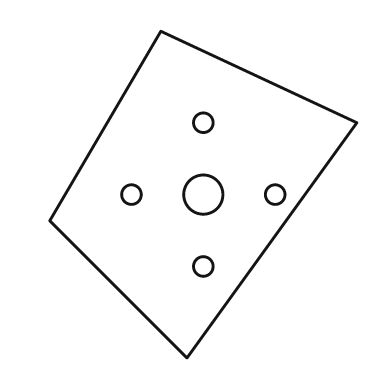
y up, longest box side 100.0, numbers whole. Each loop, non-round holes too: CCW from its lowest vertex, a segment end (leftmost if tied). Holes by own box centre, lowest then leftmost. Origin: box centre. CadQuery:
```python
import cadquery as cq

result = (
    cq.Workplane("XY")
    .moveTo(-5.0, -50.0)
    .lineTo(47.0, 22.0)
    .lineTo(-13.0, 50.0)
    .lineTo(-47.0, -8.0)
    .close()
    .moveTo(0.0, -22.0)
    .circle(3.0)
    .moveTo(-22.0, 0.0)
    .circle(3.0)
    .moveTo(0.0, 0.0)
    .circle(6.0)
    .moveTo(22.0, 0.0)
    .circle(3.0)
    .moveTo(0.0, 22.0)
    .circle(3.0)
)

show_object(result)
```